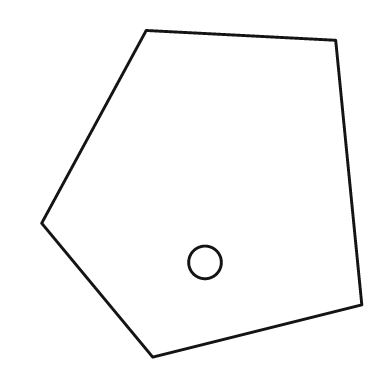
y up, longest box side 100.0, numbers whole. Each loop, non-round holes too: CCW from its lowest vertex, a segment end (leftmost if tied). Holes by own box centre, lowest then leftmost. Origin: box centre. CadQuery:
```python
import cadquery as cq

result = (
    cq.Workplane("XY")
    .moveTo(-15.0, -50.0)
    .lineTo(49.0, -34.0)
    .lineTo(41.0, 47.0)
    .lineTo(-17.0, 50.0)
    .lineTo(-49.0, -9.0)
    .close()
    .moveTo(1.0, -21.0)
    .circle(5.0)
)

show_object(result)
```